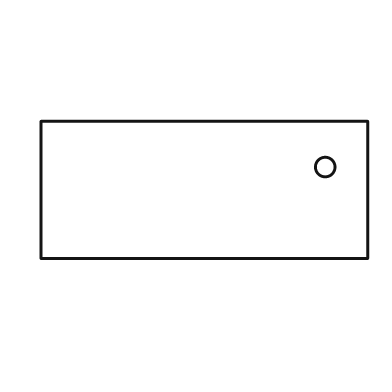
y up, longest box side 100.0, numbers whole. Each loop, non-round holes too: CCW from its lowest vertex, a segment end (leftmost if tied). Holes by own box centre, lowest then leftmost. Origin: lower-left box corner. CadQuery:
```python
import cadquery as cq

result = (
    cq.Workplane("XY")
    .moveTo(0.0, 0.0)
    .lineTo(100.0, 0.0)
    .lineTo(100.0, 42.0)
    .lineTo(0.0, 42.0)
    .close()
    .moveTo(87.0, 28.0)
    .circle(3.0)
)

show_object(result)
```